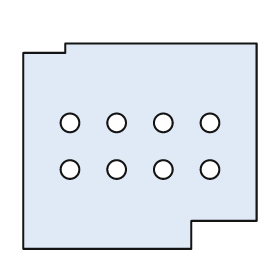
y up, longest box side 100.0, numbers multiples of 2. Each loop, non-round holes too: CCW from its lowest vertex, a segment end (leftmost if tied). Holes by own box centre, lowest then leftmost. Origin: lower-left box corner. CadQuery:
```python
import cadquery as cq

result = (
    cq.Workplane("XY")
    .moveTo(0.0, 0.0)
    .lineTo(72.0, 0.0)
    .lineTo(72.0, 12.0)
    .lineTo(100.0, 12.0)
    .lineTo(100.0, 88.0)
    .lineTo(18.0, 88.0)
    .lineTo(18.0, 84.0)
    .lineTo(0.0, 84.0)
    .close()
    .moveTo(20.0, 34.0)
    .circle(4.0)
    .moveTo(40.0, 34.0)
    .circle(4.0)
    .moveTo(60.0, 34.0)
    .circle(4.0)
    .moveTo(80.0, 34.0)
    .circle(4.0)
    .moveTo(20.0, 54.0)
    .circle(4.0)
    .moveTo(40.0, 54.0)
    .circle(4.0)
    .moveTo(60.0, 54.0)
    .circle(4.0)
    .moveTo(80.0, 54.0)
    .circle(4.0)
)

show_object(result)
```